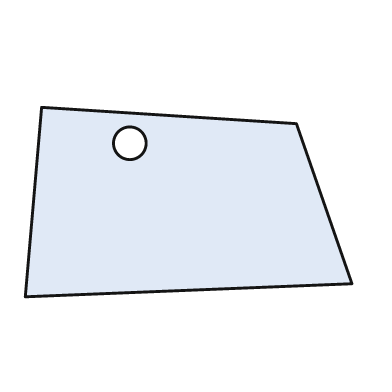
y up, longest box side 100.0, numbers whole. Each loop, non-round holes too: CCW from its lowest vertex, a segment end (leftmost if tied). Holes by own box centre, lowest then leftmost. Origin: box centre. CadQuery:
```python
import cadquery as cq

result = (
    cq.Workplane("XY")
    .moveTo(-50.0, -29.0)
    .lineTo(50.0, -25.0)
    .lineTo(33.0, 24.0)
    .lineTo(-45.0, 29.0)
    .close()
    .moveTo(-18.0, 18.0)
    .circle(5.0)
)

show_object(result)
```